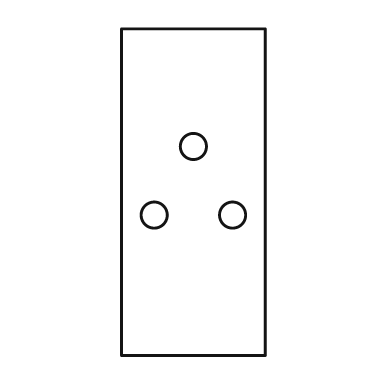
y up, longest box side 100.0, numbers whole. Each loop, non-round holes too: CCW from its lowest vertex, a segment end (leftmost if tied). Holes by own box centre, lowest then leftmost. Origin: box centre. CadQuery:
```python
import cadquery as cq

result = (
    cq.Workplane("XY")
    .moveTo(-22.0, -50.0)
    .lineTo(22.0, -50.0)
    .lineTo(22.0, 50.0)
    .lineTo(-22.0, 50.0)
    .close()
    .moveTo(-12.0, -7.0)
    .circle(4.0)
    .moveTo(12.0, -7.0)
    .circle(4.0)
    .moveTo(0.0, 14.0)
    .circle(4.0)
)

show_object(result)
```